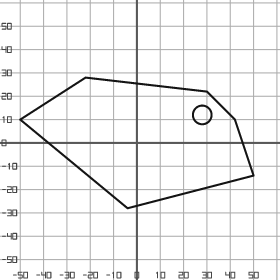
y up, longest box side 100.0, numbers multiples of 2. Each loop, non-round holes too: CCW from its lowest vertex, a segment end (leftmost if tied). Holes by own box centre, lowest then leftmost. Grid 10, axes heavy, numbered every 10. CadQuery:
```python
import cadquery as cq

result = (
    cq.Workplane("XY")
    .moveTo(-4.0, -28.0)
    .lineTo(50.0, -14.0)
    .lineTo(42.0, 10.0)
    .lineTo(30.0, 22.0)
    .lineTo(-22.0, 28.0)
    .lineTo(-50.0, 10.0)
    .close()
    .moveTo(28.0, 12.0)
    .circle(4.0)
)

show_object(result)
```